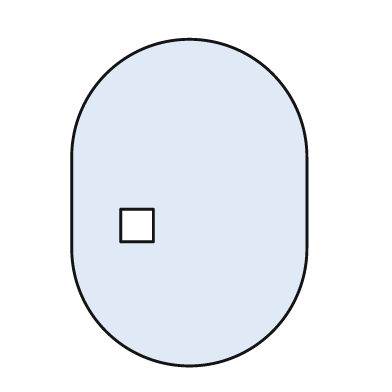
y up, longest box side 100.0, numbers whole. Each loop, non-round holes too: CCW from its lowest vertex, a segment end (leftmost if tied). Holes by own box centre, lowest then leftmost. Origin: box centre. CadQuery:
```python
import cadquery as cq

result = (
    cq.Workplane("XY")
    .moveTo(-36.0, -14.0)
    .threePointArc((0.0, -50.0), (36.0, -14.0))
    .lineTo(36.0, 14.0)
    .threePointArc((0.0, 50.0), (-36.0, 14.0))
    .close()
    .moveTo(-21.0, -12.0)
    .lineTo(-11.0, -12.0)
    .lineTo(-11.0, -2.0)
    .lineTo(-21.0, -2.0)
    .close()
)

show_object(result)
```